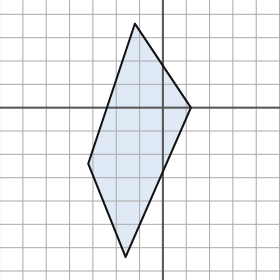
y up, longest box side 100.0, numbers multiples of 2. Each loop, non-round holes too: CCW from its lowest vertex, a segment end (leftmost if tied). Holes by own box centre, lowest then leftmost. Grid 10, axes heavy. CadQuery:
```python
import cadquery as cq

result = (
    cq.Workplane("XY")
    .moveTo(-16.0, -64.0)
    .lineTo(12.0, 0.0)
    .lineTo(-12.0, 36.0)
    .lineTo(-32.0, -24.0)
    .close()
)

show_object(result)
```